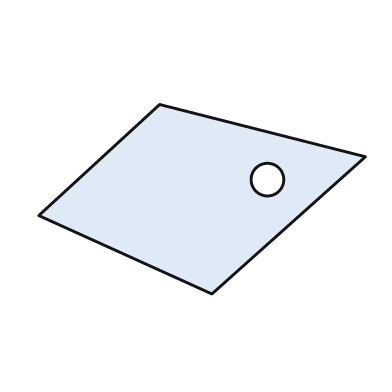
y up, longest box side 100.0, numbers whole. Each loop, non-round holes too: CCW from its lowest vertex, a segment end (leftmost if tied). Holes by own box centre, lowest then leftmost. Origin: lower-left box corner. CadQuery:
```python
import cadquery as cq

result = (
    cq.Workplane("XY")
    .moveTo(53.0, 0.0)
    .lineTo(100.0, 42.0)
    .lineTo(37.0, 58.0)
    .lineTo(0.0, 24.0)
    .close()
    .moveTo(70.0, 35.0)
    .circle(5.0)
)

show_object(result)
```